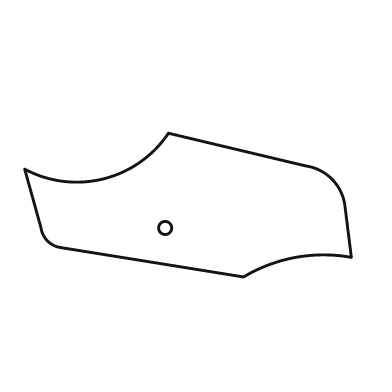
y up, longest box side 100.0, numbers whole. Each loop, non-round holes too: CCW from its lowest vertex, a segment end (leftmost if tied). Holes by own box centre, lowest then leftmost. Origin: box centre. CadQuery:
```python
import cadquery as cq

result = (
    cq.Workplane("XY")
    .moveTo(17.0, -22.0)
    .threePointArc((33.0, -16.0), (50.0, -16.0))
    .lineTo(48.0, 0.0)
    .threePointArc((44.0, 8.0), (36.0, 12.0))
    .lineTo(-6.0, 22.0)
    .threePointArc((-26.0, 8.0), (-50.0, 11.0))
    .lineTo(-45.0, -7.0)
    .threePointArc((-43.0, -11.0), (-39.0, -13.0))
    .close()
    .moveTo(-7.0, -7.0)
    .circle(2.0)
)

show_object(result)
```